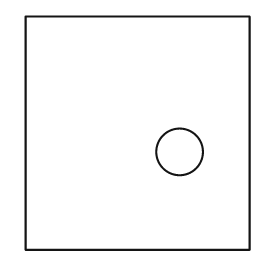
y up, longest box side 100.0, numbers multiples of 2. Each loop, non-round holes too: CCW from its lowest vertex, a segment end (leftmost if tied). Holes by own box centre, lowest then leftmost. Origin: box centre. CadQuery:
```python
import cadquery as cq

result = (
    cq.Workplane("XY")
    .moveTo(-48.0, -50.0)
    .lineTo(48.0, -50.0)
    .lineTo(48.0, 50.0)
    .lineTo(-48.0, 50.0)
    .close()
    .moveTo(18.0, -8.0)
    .circle(10.0)
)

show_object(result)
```